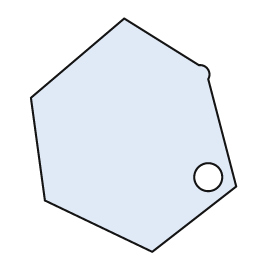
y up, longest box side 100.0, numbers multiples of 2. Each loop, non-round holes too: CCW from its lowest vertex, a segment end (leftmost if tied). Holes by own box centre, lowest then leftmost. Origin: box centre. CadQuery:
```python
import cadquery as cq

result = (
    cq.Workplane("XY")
    .moveTo(8.0, -50.0)
    .lineTo(44.0, -22.0)
    .lineTo(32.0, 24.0)
    .threePointArc((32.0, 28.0), (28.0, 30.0))
    .lineTo(-4.0, 50.0)
    .lineTo(-44.0, 16.0)
    .lineTo(-38.0, -28.0)
    .close()
    .moveTo(32.0, -18.0)
    .circle(6.0)
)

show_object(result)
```